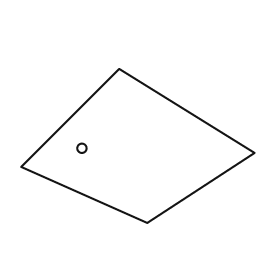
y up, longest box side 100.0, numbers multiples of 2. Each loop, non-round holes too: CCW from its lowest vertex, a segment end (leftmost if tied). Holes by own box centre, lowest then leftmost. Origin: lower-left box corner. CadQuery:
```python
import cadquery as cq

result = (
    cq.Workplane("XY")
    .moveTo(54.0, 0.0)
    .lineTo(100.0, 30.0)
    .lineTo(42.0, 66.0)
    .lineTo(0.0, 24.0)
    .close()
    .moveTo(26.0, 32.0)
    .circle(2.0)
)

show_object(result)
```